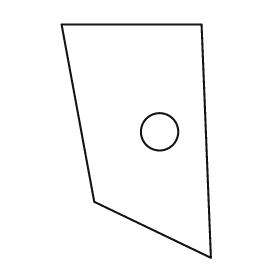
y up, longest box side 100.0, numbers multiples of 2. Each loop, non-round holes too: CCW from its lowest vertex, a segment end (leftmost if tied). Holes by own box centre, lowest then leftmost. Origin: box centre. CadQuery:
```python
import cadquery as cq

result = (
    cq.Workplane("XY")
    .moveTo(32.0, -50.0)
    .lineTo(28.0, 50.0)
    .lineTo(-32.0, 50.0)
    .lineTo(-18.0, -26.0)
    .close()
    .moveTo(10.0, 4.0)
    .circle(8.0)
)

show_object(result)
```